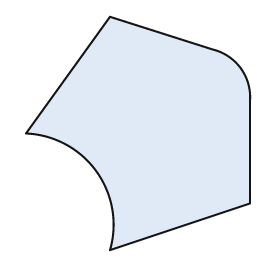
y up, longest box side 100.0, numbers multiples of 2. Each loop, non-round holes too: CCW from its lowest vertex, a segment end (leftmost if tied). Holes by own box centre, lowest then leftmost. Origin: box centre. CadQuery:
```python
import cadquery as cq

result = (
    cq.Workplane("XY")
    .moveTo(-12.0, -50.0)
    .lineTo(48.0, -30.0)
    .lineTo(48.0, 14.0)
    .threePointArc((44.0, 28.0), (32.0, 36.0))
    .lineTo(-12.0, 50.0)
    .lineTo(-48.0, 0.0)
    .threePointArc((-18.0, -16.0), (-12.0, -50.0))
    .close()
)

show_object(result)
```